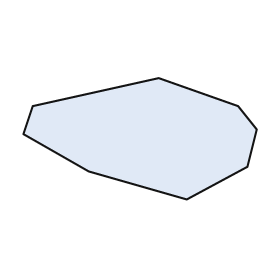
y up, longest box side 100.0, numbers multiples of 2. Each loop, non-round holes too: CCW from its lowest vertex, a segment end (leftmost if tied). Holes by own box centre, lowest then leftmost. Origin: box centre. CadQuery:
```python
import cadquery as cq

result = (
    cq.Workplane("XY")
    .moveTo(20.0, -26.0)
    .lineTo(46.0, -12.0)
    .lineTo(50.0, 4.0)
    .lineTo(42.0, 14.0)
    .lineTo(8.0, 26.0)
    .lineTo(-46.0, 14.0)
    .lineTo(-50.0, 2.0)
    .lineTo(-22.0, -14.0)
    .close()
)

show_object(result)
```